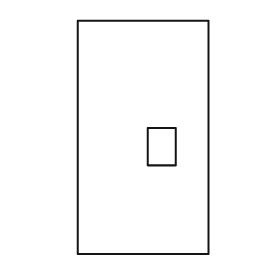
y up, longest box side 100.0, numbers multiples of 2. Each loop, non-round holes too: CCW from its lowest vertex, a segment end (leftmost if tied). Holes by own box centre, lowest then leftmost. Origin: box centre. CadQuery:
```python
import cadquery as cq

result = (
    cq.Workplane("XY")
    .moveTo(-28.0, -50.0)
    .lineTo(28.0, -50.0)
    .lineTo(28.0, 50.0)
    .lineTo(-28.0, 50.0)
    .close()
    .moveTo(2.0, -12.0)
    .lineTo(14.0, -12.0)
    .lineTo(14.0, 4.0)
    .lineTo(2.0, 4.0)
    .close()
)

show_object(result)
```